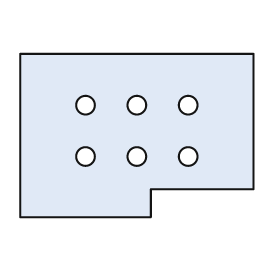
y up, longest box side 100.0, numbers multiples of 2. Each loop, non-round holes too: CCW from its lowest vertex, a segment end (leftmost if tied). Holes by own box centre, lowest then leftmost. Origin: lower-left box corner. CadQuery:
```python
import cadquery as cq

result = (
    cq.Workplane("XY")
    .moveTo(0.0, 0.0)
    .lineTo(56.0, 0.0)
    .lineTo(56.0, 12.0)
    .lineTo(100.0, 12.0)
    .lineTo(100.0, 70.0)
    .lineTo(0.0, 70.0)
    .close()
    .moveTo(28.0, 26.0)
    .circle(4.0)
    .moveTo(50.0, 26.0)
    .circle(4.0)
    .moveTo(72.0, 26.0)
    .circle(4.0)
    .moveTo(28.0, 48.0)
    .circle(4.0)
    .moveTo(50.0, 48.0)
    .circle(4.0)
    .moveTo(72.0, 48.0)
    .circle(4.0)
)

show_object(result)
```